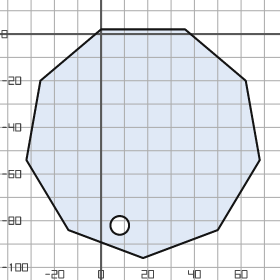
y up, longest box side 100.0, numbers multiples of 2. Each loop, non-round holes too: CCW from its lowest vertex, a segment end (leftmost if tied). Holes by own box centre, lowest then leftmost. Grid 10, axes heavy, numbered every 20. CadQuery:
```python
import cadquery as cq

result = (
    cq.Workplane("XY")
    .moveTo(18.0, -96.0)
    .lineTo(50.0, -84.0)
    .lineTo(68.0, -54.0)
    .lineTo(62.0, -20.0)
    .lineTo(36.0, 2.0)
    .lineTo(0.0, 2.0)
    .lineTo(-26.0, -20.0)
    .lineTo(-32.0, -54.0)
    .lineTo(-14.0, -84.0)
    .close()
    .moveTo(8.0, -82.0)
    .circle(4.0)
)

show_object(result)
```